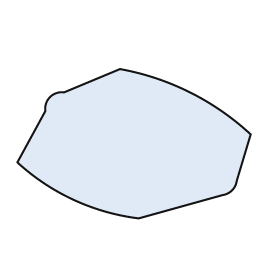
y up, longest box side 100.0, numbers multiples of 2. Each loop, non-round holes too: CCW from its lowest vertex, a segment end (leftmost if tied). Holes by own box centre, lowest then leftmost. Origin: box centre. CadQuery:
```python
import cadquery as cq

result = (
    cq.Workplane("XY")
    .moveTo(2.0, -32.0)
    .lineTo(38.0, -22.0)
    .threePointArc((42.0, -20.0), (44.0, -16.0))
    .lineTo(50.0, 4.0)
    .threePointArc((24.0, 22.0), (-6.0, 32.0))
    .lineTo(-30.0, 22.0)
    .threePointArc((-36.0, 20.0), (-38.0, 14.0))
    .lineTo(-50.0, -8.0)
    .threePointArc((-26.0, -24.0), (2.0, -32.0))
    .close()
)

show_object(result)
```